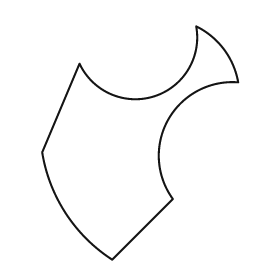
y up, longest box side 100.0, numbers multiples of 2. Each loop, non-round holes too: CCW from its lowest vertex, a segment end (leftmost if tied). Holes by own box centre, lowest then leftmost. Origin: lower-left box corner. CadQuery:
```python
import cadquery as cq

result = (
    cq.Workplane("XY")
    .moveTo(30.0, 0.0)
    .lineTo(56.0, 26.0)
    .threePointArc((54.0, 60.0), (84.0, 76.0))
    .threePointArc((78.0, 90.0), (66.0, 100.0))
    .threePointArc((48.0, 70.0), (16.0, 84.0))
    .lineTo(0.0, 46.0)
    .threePointArc((10.0, 20.0), (30.0, 0.0))
    .close()
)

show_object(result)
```